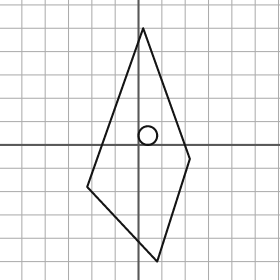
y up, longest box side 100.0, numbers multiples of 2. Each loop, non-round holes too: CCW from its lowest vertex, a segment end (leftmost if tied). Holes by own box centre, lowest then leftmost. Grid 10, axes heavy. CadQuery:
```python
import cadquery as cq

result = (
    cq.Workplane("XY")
    .moveTo(8.0, -50.0)
    .lineTo(22.0, -6.0)
    .lineTo(2.0, 50.0)
    .lineTo(-22.0, -18.0)
    .close()
    .moveTo(4.0, 4.0)
    .circle(4.0)
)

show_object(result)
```